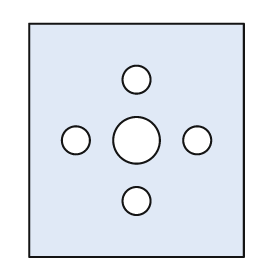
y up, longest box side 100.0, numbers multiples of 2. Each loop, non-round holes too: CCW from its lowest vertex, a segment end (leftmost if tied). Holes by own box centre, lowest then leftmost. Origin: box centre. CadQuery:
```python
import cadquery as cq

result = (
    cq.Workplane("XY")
    .moveTo(-46.0, -50.0)
    .lineTo(46.0, -50.0)
    .lineTo(46.0, 50.0)
    .lineTo(-46.0, 50.0)
    .close()
    .moveTo(0.0, -26.0)
    .circle(6.0)
    .moveTo(-26.0, 0.0)
    .circle(6.0)
    .moveTo(0.0, 0.0)
    .circle(10.0)
    .moveTo(26.0, 0.0)
    .circle(6.0)
    .moveTo(0.0, 26.0)
    .circle(6.0)
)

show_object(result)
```